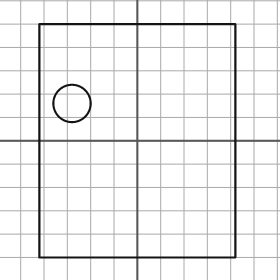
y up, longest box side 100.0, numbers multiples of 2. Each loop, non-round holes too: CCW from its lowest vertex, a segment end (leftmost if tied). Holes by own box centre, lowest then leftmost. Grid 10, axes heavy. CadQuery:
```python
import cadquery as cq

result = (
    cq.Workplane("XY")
    .moveTo(-42.0, -50.0)
    .lineTo(42.0, -50.0)
    .lineTo(42.0, 50.0)
    .lineTo(-42.0, 50.0)
    .close()
    .moveTo(-28.0, 16.0)
    .circle(8.0)
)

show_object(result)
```